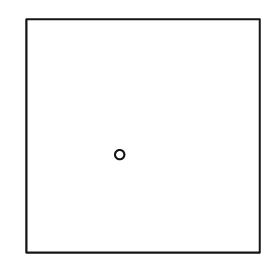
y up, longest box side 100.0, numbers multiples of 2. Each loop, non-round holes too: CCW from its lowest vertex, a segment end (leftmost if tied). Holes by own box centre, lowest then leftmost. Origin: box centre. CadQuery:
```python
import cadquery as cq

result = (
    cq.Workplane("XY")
    .moveTo(-50.0, -50.0)
    .lineTo(50.0, -50.0)
    .lineTo(50.0, 50.0)
    .lineTo(-50.0, 50.0)
    .close()
    .moveTo(-10.0, -8.0)
    .circle(2.0)
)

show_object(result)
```